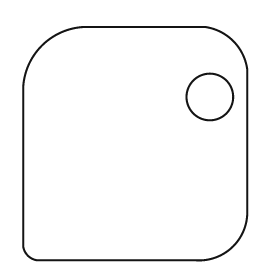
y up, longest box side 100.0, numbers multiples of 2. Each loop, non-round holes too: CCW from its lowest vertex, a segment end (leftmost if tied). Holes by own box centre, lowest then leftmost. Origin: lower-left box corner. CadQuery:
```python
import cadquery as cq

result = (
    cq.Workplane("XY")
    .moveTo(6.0, 0.0)
    .lineTo(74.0, 0.0)
    .threePointArc((90.0, 6.0), (96.0, 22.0))
    .lineTo(96.0, 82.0)
    .threePointArc((90.0, 94.0), (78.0, 100.0))
    .lineTo(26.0, 100.0)
    .threePointArc((8.0, 92.0), (0.0, 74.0))
    .lineTo(0.0, 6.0)
    .threePointArc((2.0, 2.0), (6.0, 0.0))
    .close()
    .moveTo(80.0, 70.0)
    .circle(10.0)
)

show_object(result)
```